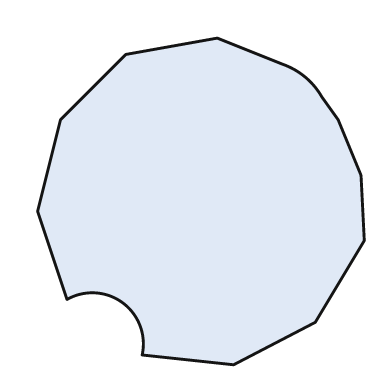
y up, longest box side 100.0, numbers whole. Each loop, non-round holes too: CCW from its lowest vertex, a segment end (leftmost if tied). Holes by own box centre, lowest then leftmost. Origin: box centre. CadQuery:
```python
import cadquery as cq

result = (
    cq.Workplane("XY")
    .moveTo(10.0, -50.0)
    .lineTo(35.0, -37.0)
    .lineTo(50.0, -12.0)
    .lineTo(49.0, 8.0)
    .lineTo(42.0, 25.0)
    .lineTo(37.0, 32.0)
    .threePointArc((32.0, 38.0), (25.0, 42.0))
    .lineTo(5.0, 50.0)
    .lineTo(-23.0, 45.0)
    .lineTo(-43.0, 25.0)
    .lineTo(-50.0, -3.0)
    .lineTo(-41.0, -30.0)
    .threePointArc((-24.0, -31.0), (-18.0, -47.0))
    .close()
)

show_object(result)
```